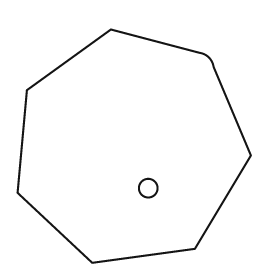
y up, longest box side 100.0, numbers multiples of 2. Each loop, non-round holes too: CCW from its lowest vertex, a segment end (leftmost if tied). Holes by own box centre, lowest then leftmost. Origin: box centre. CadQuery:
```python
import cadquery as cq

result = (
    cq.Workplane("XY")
    .moveTo(-18.0, -50.0)
    .lineTo(26.0, -44.0)
    .lineTo(50.0, -4.0)
    .lineTo(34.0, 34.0)
    .threePointArc((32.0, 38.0), (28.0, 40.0))
    .lineTo(-10.0, 50.0)
    .lineTo(-46.0, 24.0)
    .lineTo(-50.0, -20.0)
    .close()
    .moveTo(6.0, -18.0)
    .circle(4.0)
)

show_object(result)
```